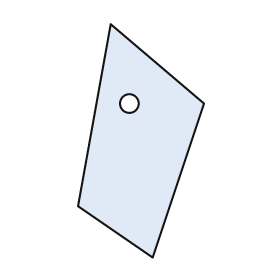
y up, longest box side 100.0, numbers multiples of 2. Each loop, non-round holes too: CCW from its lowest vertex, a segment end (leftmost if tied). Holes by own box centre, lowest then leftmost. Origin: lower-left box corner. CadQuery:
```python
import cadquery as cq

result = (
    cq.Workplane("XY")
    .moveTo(32.0, 0.0)
    .lineTo(54.0, 66.0)
    .lineTo(14.0, 100.0)
    .lineTo(0.0, 22.0)
    .close()
    .moveTo(22.0, 66.0)
    .circle(4.0)
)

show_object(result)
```